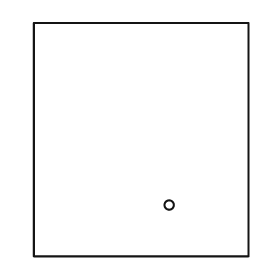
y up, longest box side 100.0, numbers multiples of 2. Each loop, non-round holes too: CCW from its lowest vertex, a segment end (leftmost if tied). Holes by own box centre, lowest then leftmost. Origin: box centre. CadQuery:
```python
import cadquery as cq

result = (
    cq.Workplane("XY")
    .moveTo(-46.0, -50.0)
    .lineTo(46.0, -50.0)
    .lineTo(46.0, 50.0)
    .lineTo(-46.0, 50.0)
    .close()
    .moveTo(12.0, -28.0)
    .circle(2.0)
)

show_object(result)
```